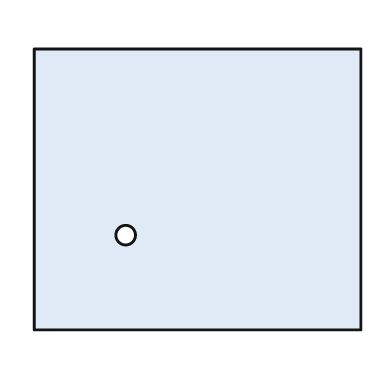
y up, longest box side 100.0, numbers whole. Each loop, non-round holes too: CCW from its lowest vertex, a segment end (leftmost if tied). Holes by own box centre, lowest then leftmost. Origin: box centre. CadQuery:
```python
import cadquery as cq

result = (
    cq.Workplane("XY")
    .moveTo(-50.0, -43.0)
    .lineTo(50.0, -43.0)
    .lineTo(50.0, 43.0)
    .lineTo(-50.0, 43.0)
    .close()
    .moveTo(-22.0, -14.0)
    .circle(3.0)
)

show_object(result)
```